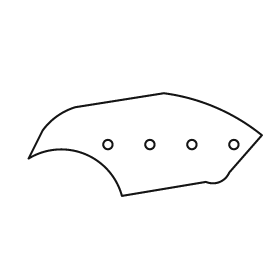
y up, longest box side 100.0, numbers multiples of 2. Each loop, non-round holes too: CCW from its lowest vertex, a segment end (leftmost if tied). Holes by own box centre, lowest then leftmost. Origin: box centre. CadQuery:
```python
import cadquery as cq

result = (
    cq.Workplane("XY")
    .moveTo(-10.0, -22.0)
    .lineTo(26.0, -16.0)
    .threePointArc((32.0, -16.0), (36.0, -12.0))
    .lineTo(50.0, 4.0)
    .threePointArc((30.0, 16.0), (8.0, 22.0))
    .lineTo(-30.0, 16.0)
    .threePointArc((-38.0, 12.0), (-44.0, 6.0))
    .lineTo(-50.0, -6.0)
    .threePointArc((-26.0, -4.0), (-10.0, -22.0))
    .close()
    .moveTo(-16.0, 0.0)
    .circle(2.0)
    .moveTo(2.0, 0.0)
    .circle(2.0)
    .moveTo(20.0, 0.0)
    .circle(2.0)
    .moveTo(38.0, 0.0)
    .circle(2.0)
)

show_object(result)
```